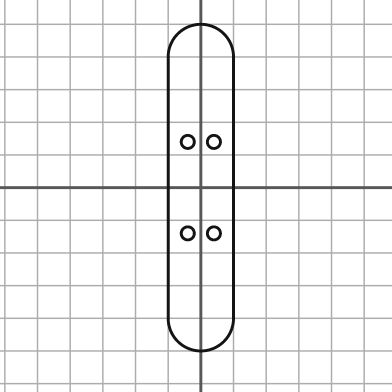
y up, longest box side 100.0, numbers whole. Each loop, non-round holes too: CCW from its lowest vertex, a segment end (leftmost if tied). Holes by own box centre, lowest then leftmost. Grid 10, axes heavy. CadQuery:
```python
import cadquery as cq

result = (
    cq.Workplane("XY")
    .moveTo(-10.0, -40.0)
    .threePointArc((0.0, -50.0), (10.0, -40.0))
    .lineTo(10.0, 40.0)
    .threePointArc((0.0, 50.0), (-10.0, 40.0))
    .close()
    .moveTo(-4.0, -14.0)
    .circle(2.0)
    .moveTo(4.0, -14.0)
    .circle(2.0)
    .moveTo(-4.0, 14.0)
    .circle(2.0)
    .moveTo(4.0, 14.0)
    .circle(2.0)
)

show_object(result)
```